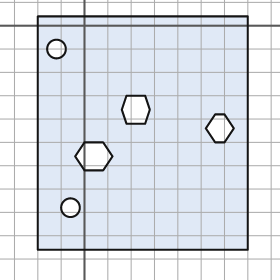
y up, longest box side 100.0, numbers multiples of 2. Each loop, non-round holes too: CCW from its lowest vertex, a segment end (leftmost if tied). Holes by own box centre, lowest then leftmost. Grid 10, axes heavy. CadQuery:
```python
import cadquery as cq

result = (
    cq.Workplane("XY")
    .moveTo(-20.0, -96.0)
    .lineTo(70.0, -96.0)
    .lineTo(70.0, 4.0)
    .lineTo(-20.0, 4.0)
    .close()
    .moveTo(-6.0, -78.0)
    .circle(4.0)
    .moveTo(0.0, -62.0)
    .lineTo(8.0, -62.0)
    .lineTo(12.0, -56.0)
    .lineTo(8.0, -50.0)
    .lineTo(0.0, -50.0)
    .lineTo(-4.0, -56.0)
    .close()
    .moveTo(56.0, -50.0)
    .lineTo(60.0, -50.0)
    .lineTo(64.0, -44.0)
    .lineTo(60.0, -38.0)
    .lineTo(56.0, -38.0)
    .lineTo(52.0, -44.0)
    .close()
    .moveTo(18.0, -42.0)
    .lineTo(26.0, -42.0)
    .lineTo(28.0, -36.0)
    .lineTo(26.0, -30.0)
    .lineTo(18.0, -30.0)
    .lineTo(16.0, -36.0)
    .close()
    .moveTo(-12.0, -10.0)
    .circle(4.0)
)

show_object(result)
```